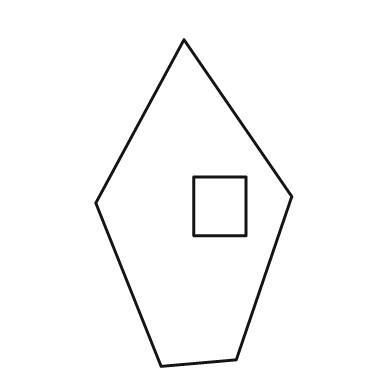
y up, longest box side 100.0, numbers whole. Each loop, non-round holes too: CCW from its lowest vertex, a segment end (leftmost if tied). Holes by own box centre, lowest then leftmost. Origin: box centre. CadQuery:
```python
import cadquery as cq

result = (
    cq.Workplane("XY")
    .moveTo(-10.0, -50.0)
    .lineTo(13.0, -48.0)
    .lineTo(30.0, 2.0)
    .lineTo(-3.0, 50.0)
    .lineTo(-30.0, 0.0)
    .close()
    .moveTo(0.0, -10.0)
    .lineTo(16.0, -10.0)
    .lineTo(16.0, 8.0)
    .lineTo(0.0, 8.0)
    .close()
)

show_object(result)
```